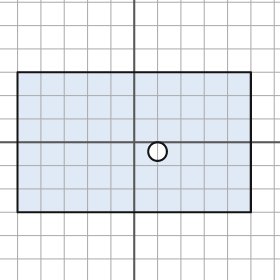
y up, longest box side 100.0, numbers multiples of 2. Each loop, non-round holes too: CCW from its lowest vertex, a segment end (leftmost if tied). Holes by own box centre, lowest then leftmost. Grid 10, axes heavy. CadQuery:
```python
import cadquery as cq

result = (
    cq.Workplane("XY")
    .moveTo(-50.0, -30.0)
    .lineTo(50.0, -30.0)
    .lineTo(50.0, 30.0)
    .lineTo(-50.0, 30.0)
    .close()
    .moveTo(10.0, -4.0)
    .circle(4.0)
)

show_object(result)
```